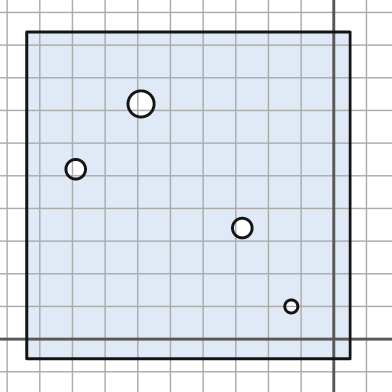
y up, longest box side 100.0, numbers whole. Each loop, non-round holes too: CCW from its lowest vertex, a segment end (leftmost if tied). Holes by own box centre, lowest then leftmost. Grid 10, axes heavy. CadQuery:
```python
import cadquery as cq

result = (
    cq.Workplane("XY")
    .moveTo(-94.0, -6.0)
    .lineTo(5.0, -6.0)
    .lineTo(5.0, 94.0)
    .lineTo(-94.0, 94.0)
    .close()
    .moveTo(-13.0, 10.0)
    .circle(2.0)
    .moveTo(-28.0, 34.0)
    .circle(3.0)
    .moveTo(-79.0, 52.0)
    .circle(3.0)
    .moveTo(-59.0, 72.0)
    .circle(4.0)
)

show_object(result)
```